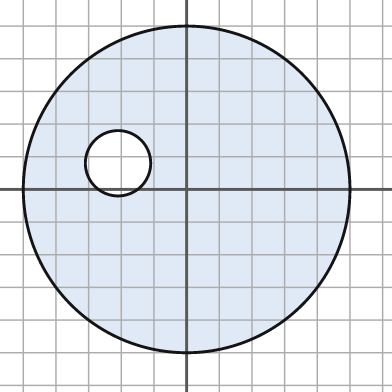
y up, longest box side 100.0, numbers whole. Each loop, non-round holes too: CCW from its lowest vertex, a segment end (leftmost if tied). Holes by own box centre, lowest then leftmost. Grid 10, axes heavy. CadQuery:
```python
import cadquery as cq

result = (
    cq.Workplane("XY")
    .moveTo(0.0, 0.0)
    .circle(50.0)
    .moveTo(-21.0, 8.0)
    .circle(10.0)
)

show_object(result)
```